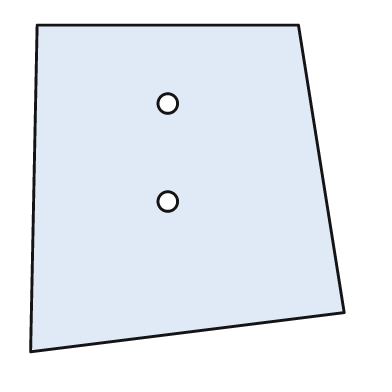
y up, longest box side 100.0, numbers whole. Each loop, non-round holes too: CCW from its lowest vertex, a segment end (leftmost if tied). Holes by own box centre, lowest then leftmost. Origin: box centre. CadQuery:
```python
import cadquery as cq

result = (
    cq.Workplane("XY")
    .moveTo(-48.0, -50.0)
    .lineTo(48.0, -38.0)
    .lineTo(34.0, 50.0)
    .lineTo(-46.0, 50.0)
    .close()
    .moveTo(-6.0, -4.0)
    .circle(3.0)
    .moveTo(-6.0, 26.0)
    .circle(3.0)
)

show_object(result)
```